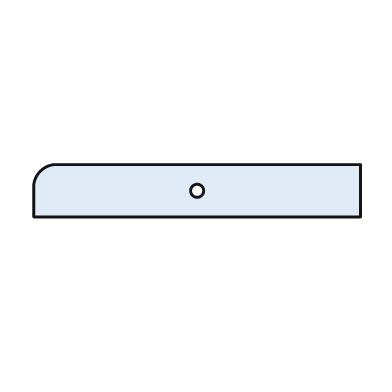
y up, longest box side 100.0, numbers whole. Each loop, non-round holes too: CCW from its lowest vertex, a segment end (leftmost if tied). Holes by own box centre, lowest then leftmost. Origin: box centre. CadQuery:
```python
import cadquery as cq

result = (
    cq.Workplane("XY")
    .moveTo(-50.0, -8.0)
    .lineTo(50.0, -8.0)
    .lineTo(50.0, 8.0)
    .lineTo(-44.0, 8.0)
    .threePointArc((-48.0, 6.0), (-50.0, 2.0))
    .close()
    .moveTo(0.0, 0.0)
    .circle(2.0)
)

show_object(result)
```